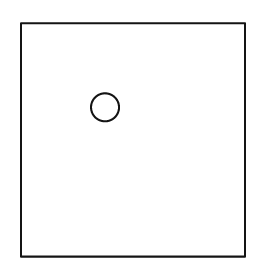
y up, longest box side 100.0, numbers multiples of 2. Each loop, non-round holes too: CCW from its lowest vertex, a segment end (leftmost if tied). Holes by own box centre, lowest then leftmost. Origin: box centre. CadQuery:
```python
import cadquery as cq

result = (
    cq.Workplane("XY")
    .moveTo(-48.0, -50.0)
    .lineTo(48.0, -50.0)
    .lineTo(48.0, 50.0)
    .lineTo(-48.0, 50.0)
    .close()
    .moveTo(-12.0, 14.0)
    .circle(6.0)
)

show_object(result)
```